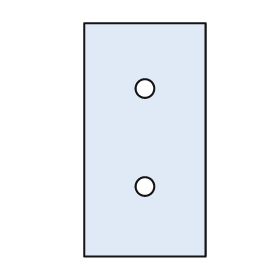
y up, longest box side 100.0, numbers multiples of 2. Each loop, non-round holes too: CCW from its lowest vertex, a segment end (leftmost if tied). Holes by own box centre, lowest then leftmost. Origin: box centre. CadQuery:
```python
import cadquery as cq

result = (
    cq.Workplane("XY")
    .moveTo(-26.0, -50.0)
    .lineTo(26.0, -50.0)
    .lineTo(26.0, 50.0)
    .lineTo(-26.0, 50.0)
    .close()
    .moveTo(0.0, -20.0)
    .circle(4.0)
    .moveTo(0.0, 22.0)
    .circle(4.0)
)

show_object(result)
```